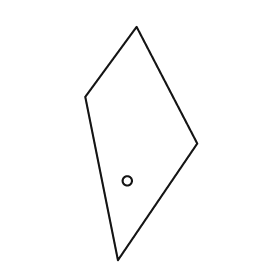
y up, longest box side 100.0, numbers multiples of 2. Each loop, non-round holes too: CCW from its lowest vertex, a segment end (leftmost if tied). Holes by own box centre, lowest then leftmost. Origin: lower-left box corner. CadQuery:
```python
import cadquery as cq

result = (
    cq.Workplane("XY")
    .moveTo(14.0, 0.0)
    .lineTo(48.0, 50.0)
    .lineTo(22.0, 100.0)
    .lineTo(0.0, 70.0)
    .close()
    .moveTo(18.0, 34.0)
    .circle(2.0)
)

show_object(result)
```